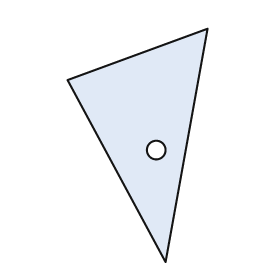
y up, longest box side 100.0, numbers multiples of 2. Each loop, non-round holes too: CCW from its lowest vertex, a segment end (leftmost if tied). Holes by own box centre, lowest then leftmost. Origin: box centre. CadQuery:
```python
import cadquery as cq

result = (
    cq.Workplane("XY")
    .moveTo(12.0, -50.0)
    .lineTo(30.0, 50.0)
    .lineTo(-30.0, 28.0)
    .close()
    .moveTo(8.0, -2.0)
    .circle(4.0)
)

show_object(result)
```